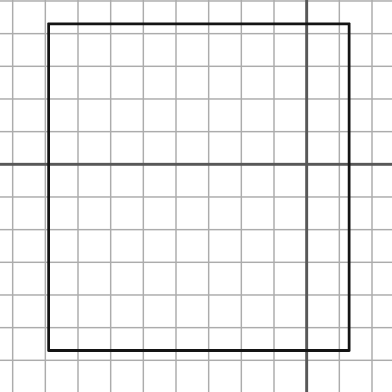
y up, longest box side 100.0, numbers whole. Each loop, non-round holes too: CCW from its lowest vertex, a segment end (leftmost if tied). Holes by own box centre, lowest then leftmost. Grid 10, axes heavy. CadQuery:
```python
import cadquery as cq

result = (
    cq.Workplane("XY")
    .moveTo(-79.0, -57.0)
    .lineTo(13.0, -57.0)
    .lineTo(13.0, 43.0)
    .lineTo(-79.0, 43.0)
    .close()
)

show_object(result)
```